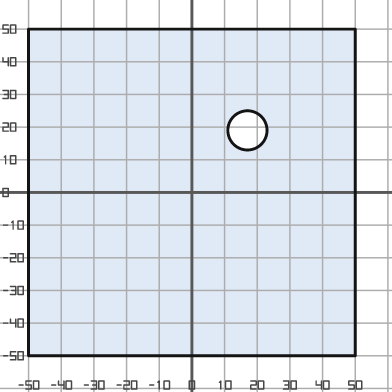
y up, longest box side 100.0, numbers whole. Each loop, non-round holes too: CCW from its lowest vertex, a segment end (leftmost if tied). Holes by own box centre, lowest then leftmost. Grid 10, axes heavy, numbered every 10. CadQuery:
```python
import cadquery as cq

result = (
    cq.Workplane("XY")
    .moveTo(-50.0, -50.0)
    .lineTo(50.0, -50.0)
    .lineTo(50.0, 50.0)
    .lineTo(-50.0, 50.0)
    .close()
    .moveTo(17.0, 19.0)
    .circle(6.0)
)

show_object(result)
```